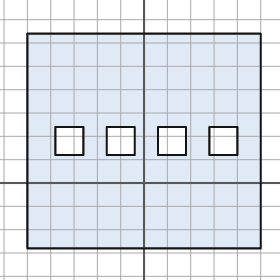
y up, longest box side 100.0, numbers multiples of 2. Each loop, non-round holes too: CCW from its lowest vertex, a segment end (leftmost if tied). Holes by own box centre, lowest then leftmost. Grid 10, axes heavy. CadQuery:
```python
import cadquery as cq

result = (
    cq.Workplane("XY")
    .moveTo(-50.0, -28.0)
    .lineTo(50.0, -28.0)
    .lineTo(50.0, 64.0)
    .lineTo(-50.0, 64.0)
    .close()
    .moveTo(-38.0, 12.0)
    .lineTo(-26.0, 12.0)
    .lineTo(-26.0, 24.0)
    .lineTo(-38.0, 24.0)
    .close()
    .moveTo(-16.0, 12.0)
    .lineTo(-4.0, 12.0)
    .lineTo(-4.0, 24.0)
    .lineTo(-16.0, 24.0)
    .close()
    .moveTo(6.0, 12.0)
    .lineTo(18.0, 12.0)
    .lineTo(18.0, 24.0)
    .lineTo(6.0, 24.0)
    .close()
    .moveTo(28.0, 12.0)
    .lineTo(40.0, 12.0)
    .lineTo(40.0, 24.0)
    .lineTo(28.0, 24.0)
    .close()
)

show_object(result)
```